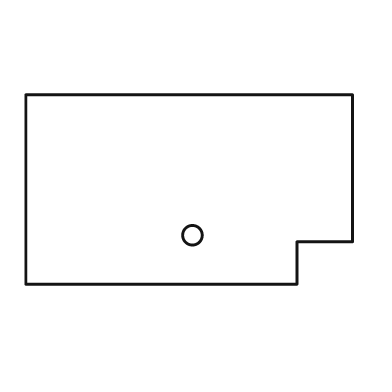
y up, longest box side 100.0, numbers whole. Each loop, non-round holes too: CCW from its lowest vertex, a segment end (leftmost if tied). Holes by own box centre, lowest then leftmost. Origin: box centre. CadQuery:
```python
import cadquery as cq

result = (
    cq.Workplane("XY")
    .moveTo(-50.0, -29.0)
    .lineTo(33.0, -29.0)
    .lineTo(33.0, -16.0)
    .lineTo(50.0, -16.0)
    .lineTo(50.0, 29.0)
    .lineTo(-50.0, 29.0)
    .close()
    .moveTo(1.0, -14.0)
    .circle(3.0)
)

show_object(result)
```